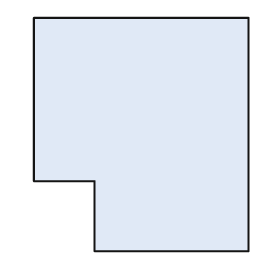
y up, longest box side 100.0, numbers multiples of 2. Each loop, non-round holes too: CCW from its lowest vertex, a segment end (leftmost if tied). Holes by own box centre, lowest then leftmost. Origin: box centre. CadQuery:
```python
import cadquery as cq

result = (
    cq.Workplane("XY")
    .moveTo(-20.0, -50.0)
    .lineTo(46.0, -50.0)
    .lineTo(46.0, 50.0)
    .lineTo(-46.0, 50.0)
    .lineTo(-46.0, -20.0)
    .lineTo(-20.0, -20.0)
    .close()
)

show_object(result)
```